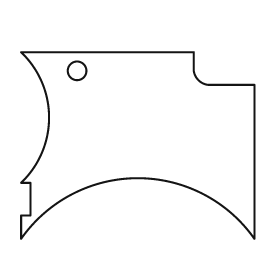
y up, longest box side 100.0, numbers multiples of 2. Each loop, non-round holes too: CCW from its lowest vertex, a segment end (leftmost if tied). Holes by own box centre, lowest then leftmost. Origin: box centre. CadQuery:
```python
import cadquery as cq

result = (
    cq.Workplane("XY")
    .moveTo(-50.0, -40.0)
    .threePointArc((0.0, -14.0), (50.0, -40.0))
    .lineTo(50.0, 26.0)
    .lineTo(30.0, 26.0)
    .threePointArc((26.0, 28.0), (24.0, 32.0))
    .lineTo(24.0, 40.0)
    .lineTo(-50.0, 40.0)
    .threePointArc((-38.0, 12.0), (-50.0, -16.0))
    .lineTo(-46.0, -16.0)
    .lineTo(-46.0, -30.0)
    .lineTo(-50.0, -30.0)
    .close()
    .moveTo(-26.0, 32.0)
    .circle(4.0)
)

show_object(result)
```